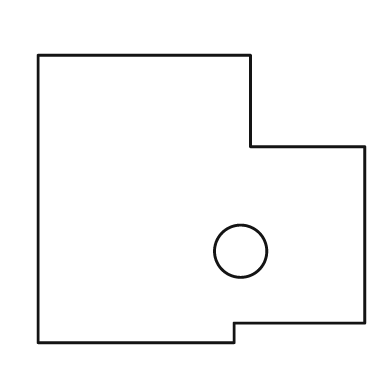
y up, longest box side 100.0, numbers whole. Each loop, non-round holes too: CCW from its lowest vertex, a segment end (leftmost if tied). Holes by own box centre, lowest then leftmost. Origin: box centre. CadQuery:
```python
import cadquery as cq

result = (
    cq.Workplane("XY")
    .moveTo(-50.0, -44.0)
    .lineTo(10.0, -44.0)
    .lineTo(10.0, -38.0)
    .lineTo(50.0, -38.0)
    .lineTo(50.0, 16.0)
    .lineTo(15.0, 16.0)
    .lineTo(15.0, 44.0)
    .lineTo(-50.0, 44.0)
    .close()
    .moveTo(12.0, -16.0)
    .circle(8.0)
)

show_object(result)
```